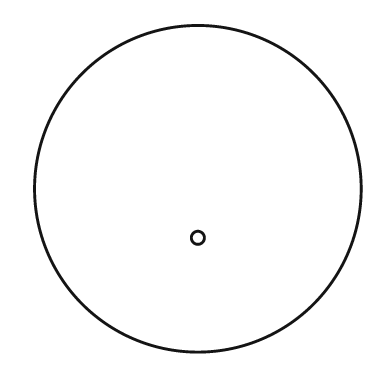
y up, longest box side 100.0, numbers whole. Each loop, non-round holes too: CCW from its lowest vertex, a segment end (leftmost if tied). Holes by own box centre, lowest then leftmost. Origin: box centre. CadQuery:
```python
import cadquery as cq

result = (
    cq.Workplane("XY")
    .moveTo(0.0, 0.0)
    .circle(50.0)
    .moveTo(0.0, -15.0)
    .circle(2.0)
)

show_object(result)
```